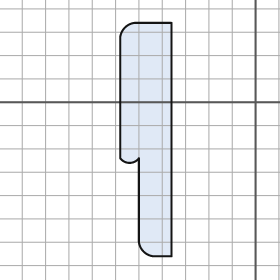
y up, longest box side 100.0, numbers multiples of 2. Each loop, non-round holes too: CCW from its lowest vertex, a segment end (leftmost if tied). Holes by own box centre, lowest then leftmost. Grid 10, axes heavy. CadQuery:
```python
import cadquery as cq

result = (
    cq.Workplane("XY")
    .moveTo(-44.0, -66.0)
    .lineTo(-36.0, -66.0)
    .lineTo(-36.0, 34.0)
    .lineTo(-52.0, 34.0)
    .threePointArc((-56.0, 32.0), (-58.0, 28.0))
    .lineTo(-58.0, -24.0)
    .threePointArc((-54.0, -26.0), (-50.0, -24.0))
    .lineTo(-50.0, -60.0)
    .threePointArc((-48.0, -64.0), (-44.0, -66.0))
    .close()
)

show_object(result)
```